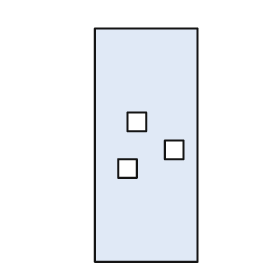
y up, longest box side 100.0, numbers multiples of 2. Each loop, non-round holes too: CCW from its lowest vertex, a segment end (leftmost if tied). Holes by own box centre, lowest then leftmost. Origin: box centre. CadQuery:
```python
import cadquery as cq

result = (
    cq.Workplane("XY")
    .moveTo(-22.0, -50.0)
    .lineTo(22.0, -50.0)
    .lineTo(22.0, 50.0)
    .lineTo(-22.0, 50.0)
    .close()
    .moveTo(-12.0, -14.0)
    .lineTo(-4.0, -14.0)
    .lineTo(-4.0, -6.0)
    .lineTo(-12.0, -6.0)
    .close()
    .moveTo(8.0, -6.0)
    .lineTo(16.0, -6.0)
    .lineTo(16.0, 2.0)
    .lineTo(8.0, 2.0)
    .close()
    .moveTo(-8.0, 6.0)
    .lineTo(0.0, 6.0)
    .lineTo(0.0, 14.0)
    .lineTo(-8.0, 14.0)
    .close()
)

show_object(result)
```